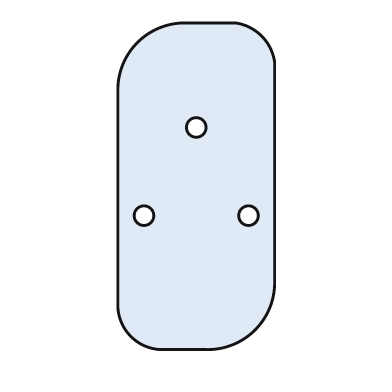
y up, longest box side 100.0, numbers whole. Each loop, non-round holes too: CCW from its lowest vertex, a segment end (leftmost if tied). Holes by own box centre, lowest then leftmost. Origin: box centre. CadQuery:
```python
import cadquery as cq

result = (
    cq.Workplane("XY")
    .moveTo(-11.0, -50.0)
    .lineTo(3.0, -50.0)
    .threePointArc((18.0, -44.0), (24.0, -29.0))
    .lineTo(24.0, 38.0)
    .threePointArc((20.0, 46.0), (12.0, 50.0))
    .lineTo(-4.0, 50.0)
    .threePointArc((-18.0, 44.0), (-24.0, 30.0))
    .lineTo(-24.0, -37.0)
    .threePointArc((-20.0, -46.0), (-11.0, -50.0))
    .close()
    .moveTo(-16.0, -9.0)
    .circle(3.0)
    .moveTo(16.0, -9.0)
    .circle(3.0)
    .moveTo(0.0, 18.0)
    .circle(3.0)
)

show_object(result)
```